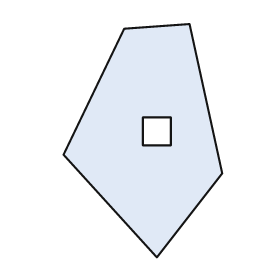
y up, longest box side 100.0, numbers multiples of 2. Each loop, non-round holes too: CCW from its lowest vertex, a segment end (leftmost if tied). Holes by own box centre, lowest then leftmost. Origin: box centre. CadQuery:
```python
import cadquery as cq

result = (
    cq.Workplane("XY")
    .moveTo(6.0, -50.0)
    .lineTo(34.0, -14.0)
    .lineTo(20.0, 50.0)
    .lineTo(-8.0, 48.0)
    .lineTo(-34.0, -6.0)
    .close()
    .moveTo(0.0, -2.0)
    .lineTo(12.0, -2.0)
    .lineTo(12.0, 10.0)
    .lineTo(0.0, 10.0)
    .close()
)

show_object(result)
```